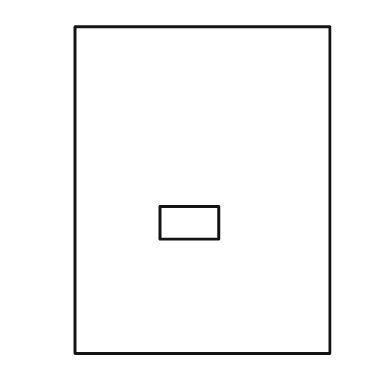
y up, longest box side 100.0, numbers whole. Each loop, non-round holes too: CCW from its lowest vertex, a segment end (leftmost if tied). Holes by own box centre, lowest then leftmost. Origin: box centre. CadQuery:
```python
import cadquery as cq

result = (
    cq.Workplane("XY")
    .moveTo(-39.0, -50.0)
    .lineTo(39.0, -50.0)
    .lineTo(39.0, 50.0)
    .lineTo(-39.0, 50.0)
    .close()
    .moveTo(-13.0, -15.0)
    .lineTo(5.0, -15.0)
    .lineTo(5.0, -5.0)
    .lineTo(-13.0, -5.0)
    .close()
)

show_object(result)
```